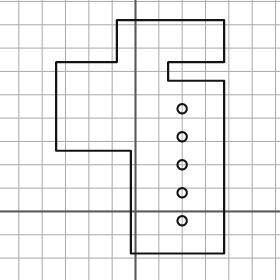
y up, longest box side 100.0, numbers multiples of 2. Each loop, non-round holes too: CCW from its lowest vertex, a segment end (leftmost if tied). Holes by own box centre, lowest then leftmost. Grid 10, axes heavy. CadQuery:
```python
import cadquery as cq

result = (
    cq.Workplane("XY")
    .moveTo(-2.0, -18.0)
    .lineTo(38.0, -18.0)
    .lineTo(38.0, 56.0)
    .lineTo(14.0, 56.0)
    .lineTo(14.0, 64.0)
    .lineTo(38.0, 64.0)
    .lineTo(38.0, 82.0)
    .lineTo(-8.0, 82.0)
    .lineTo(-8.0, 64.0)
    .lineTo(-34.0, 64.0)
    .lineTo(-34.0, 26.0)
    .lineTo(-2.0, 26.0)
    .close()
    .moveTo(20.0, -4.0)
    .circle(2.0)
    .moveTo(20.0, 8.0)
    .circle(2.0)
    .moveTo(20.0, 20.0)
    .circle(2.0)
    .moveTo(20.0, 32.0)
    .circle(2.0)
    .moveTo(20.0, 44.0)
    .circle(2.0)
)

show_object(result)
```